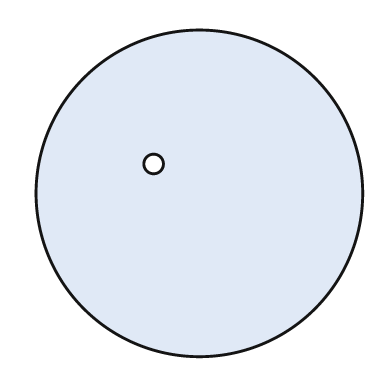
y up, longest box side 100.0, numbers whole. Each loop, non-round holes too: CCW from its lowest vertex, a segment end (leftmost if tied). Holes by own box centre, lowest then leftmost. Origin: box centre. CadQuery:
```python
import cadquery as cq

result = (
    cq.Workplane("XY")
    .moveTo(0.0, 0.0)
    .circle(50.0)
    .moveTo(-14.0, 9.0)
    .circle(3.0)
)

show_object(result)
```